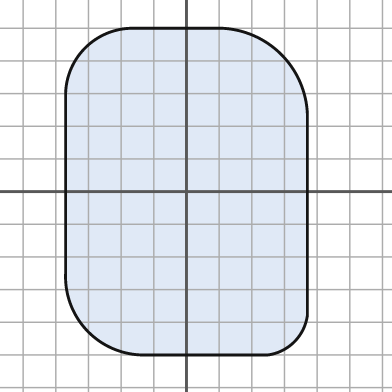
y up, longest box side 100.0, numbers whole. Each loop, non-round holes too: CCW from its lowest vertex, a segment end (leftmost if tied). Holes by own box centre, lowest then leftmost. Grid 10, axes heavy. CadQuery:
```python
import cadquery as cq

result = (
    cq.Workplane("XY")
    .moveTo(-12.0, -50.0)
    .lineTo(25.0, -50.0)
    .threePointArc((33.0, -46.0), (37.0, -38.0))
    .lineTo(37.0, 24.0)
    .threePointArc((29.0, 42.0), (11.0, 50.0))
    .lineTo(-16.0, 50.0)
    .threePointArc((-31.0, 44.0), (-37.0, 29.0))
    .lineTo(-37.0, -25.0)
    .threePointArc((-30.0, -43.0), (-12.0, -50.0))
    .close()
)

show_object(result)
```